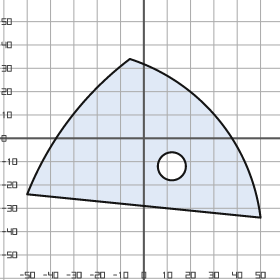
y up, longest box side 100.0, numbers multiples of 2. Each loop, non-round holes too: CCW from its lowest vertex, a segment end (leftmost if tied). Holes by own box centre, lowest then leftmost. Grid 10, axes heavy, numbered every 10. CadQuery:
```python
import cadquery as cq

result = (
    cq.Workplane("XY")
    .moveTo(50.0, -34.0)
    .threePointArc((32.0, 8.0), (-6.0, 34.0))
    .threePointArc((-32.0, 8.0), (-50.0, -24.0))
    .close()
    .moveTo(12.0, -12.0)
    .circle(6.0)
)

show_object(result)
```